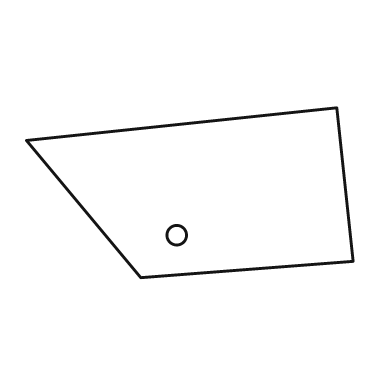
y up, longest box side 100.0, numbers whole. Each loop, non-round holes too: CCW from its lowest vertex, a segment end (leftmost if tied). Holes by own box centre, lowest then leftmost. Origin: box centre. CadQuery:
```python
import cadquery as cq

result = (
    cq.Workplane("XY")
    .moveTo(-15.0, -26.0)
    .lineTo(50.0, -21.0)
    .lineTo(45.0, 26.0)
    .lineTo(-50.0, 16.0)
    .close()
    .moveTo(-4.0, -13.0)
    .circle(3.0)
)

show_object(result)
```